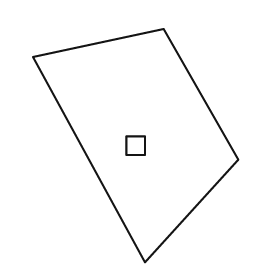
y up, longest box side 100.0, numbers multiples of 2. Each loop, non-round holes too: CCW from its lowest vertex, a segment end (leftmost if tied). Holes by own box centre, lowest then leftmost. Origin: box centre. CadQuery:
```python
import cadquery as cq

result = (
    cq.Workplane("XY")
    .moveTo(4.0, -50.0)
    .lineTo(44.0, -6.0)
    .lineTo(12.0, 50.0)
    .lineTo(-44.0, 38.0)
    .close()
    .moveTo(-4.0, -4.0)
    .lineTo(4.0, -4.0)
    .lineTo(4.0, 4.0)
    .lineTo(-4.0, 4.0)
    .close()
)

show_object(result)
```